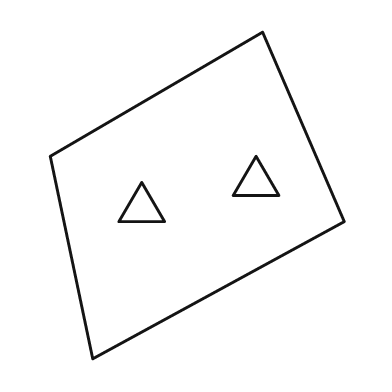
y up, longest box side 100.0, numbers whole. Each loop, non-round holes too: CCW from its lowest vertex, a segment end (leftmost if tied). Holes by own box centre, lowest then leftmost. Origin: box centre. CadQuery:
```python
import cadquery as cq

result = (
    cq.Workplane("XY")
    .moveTo(-32.0, -50.0)
    .lineTo(45.0, -8.0)
    .lineTo(20.0, 50.0)
    .lineTo(-45.0, 12.0)
    .close()
    .moveTo(-24.0, -8.0)
    .lineTo(-10.0, -8.0)
    .lineTo(-17.0, 4.0)
    .close()
    .moveTo(11.0, 0.0)
    .lineTo(25.0, 0.0)
    .lineTo(18.0, 12.0)
    .close()
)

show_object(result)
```